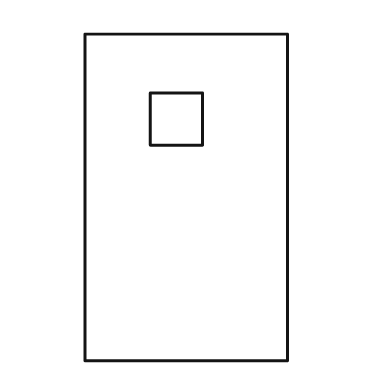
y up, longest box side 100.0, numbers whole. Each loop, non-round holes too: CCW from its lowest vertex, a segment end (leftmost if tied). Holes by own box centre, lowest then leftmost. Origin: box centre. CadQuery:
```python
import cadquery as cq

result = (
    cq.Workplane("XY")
    .moveTo(-31.0, -50.0)
    .lineTo(31.0, -50.0)
    .lineTo(31.0, 50.0)
    .lineTo(-31.0, 50.0)
    .close()
    .moveTo(-11.0, 16.0)
    .lineTo(5.0, 16.0)
    .lineTo(5.0, 32.0)
    .lineTo(-11.0, 32.0)
    .close()
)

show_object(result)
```